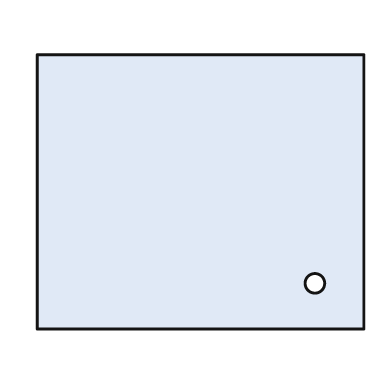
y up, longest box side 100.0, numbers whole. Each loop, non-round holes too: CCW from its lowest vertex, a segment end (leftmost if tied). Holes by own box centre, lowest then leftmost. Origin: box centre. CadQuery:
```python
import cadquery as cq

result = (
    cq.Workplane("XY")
    .moveTo(-50.0, -42.0)
    .lineTo(50.0, -42.0)
    .lineTo(50.0, 42.0)
    .lineTo(-50.0, 42.0)
    .close()
    .moveTo(35.0, -28.0)
    .circle(3.0)
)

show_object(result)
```